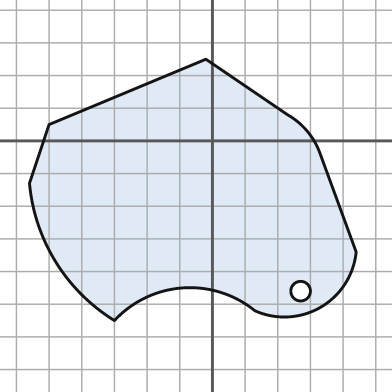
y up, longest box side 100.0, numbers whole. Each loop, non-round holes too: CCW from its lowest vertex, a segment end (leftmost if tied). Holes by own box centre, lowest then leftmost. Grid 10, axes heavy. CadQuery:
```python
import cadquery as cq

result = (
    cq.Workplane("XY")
    .moveTo(-30.0, -55.0)
    .threePointArc((-9.0, -45.0), (13.0, -52.0))
    .threePointArc((33.0, -51.0), (44.0, -34.0))
    .lineTo(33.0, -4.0)
    .threePointArc((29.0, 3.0), (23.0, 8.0))
    .lineTo(-2.0, 25.0)
    .lineTo(-50.0, 5.0)
    .lineTo(-56.0, -13.0)
    .threePointArc((-48.0, -37.0), (-30.0, -55.0))
    .close()
    .moveTo(27.0, -46.0)
    .circle(3.0)
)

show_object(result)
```